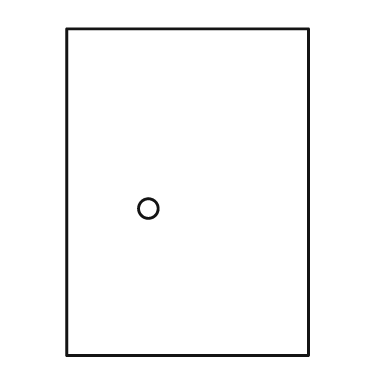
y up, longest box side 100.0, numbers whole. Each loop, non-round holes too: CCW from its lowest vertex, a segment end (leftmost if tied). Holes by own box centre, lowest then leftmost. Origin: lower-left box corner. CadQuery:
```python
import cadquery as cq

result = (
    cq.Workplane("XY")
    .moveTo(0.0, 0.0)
    .lineTo(74.0, 0.0)
    .lineTo(74.0, 100.0)
    .lineTo(0.0, 100.0)
    .close()
    .moveTo(25.0, 45.0)
    .circle(3.0)
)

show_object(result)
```